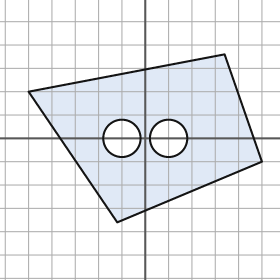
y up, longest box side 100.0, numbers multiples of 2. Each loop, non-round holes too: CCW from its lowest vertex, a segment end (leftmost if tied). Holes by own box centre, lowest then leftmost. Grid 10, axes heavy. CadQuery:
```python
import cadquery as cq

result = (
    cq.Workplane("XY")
    .moveTo(-12.0, -36.0)
    .lineTo(50.0, -10.0)
    .lineTo(34.0, 36.0)
    .lineTo(-50.0, 20.0)
    .close()
    .moveTo(-10.0, 0.0)
    .circle(8.0)
    .moveTo(10.0, 0.0)
    .circle(8.0)
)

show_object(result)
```